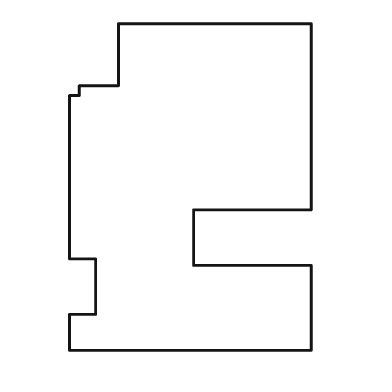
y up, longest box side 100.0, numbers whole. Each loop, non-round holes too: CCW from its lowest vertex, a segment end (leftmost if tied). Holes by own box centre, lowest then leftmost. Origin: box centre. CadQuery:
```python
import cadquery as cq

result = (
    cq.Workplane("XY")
    .moveTo(-37.0, -50.0)
    .lineTo(37.0, -50.0)
    .lineTo(37.0, -24.0)
    .lineTo(1.0, -24.0)
    .lineTo(1.0, -7.0)
    .lineTo(37.0, -7.0)
    .lineTo(37.0, 50.0)
    .lineTo(-22.0, 50.0)
    .lineTo(-22.0, 31.0)
    .lineTo(-34.0, 31.0)
    .lineTo(-34.0, 28.0)
    .lineTo(-37.0, 28.0)
    .lineTo(-37.0, -22.0)
    .lineTo(-29.0, -22.0)
    .lineTo(-29.0, -39.0)
    .lineTo(-37.0, -39.0)
    .close()
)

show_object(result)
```